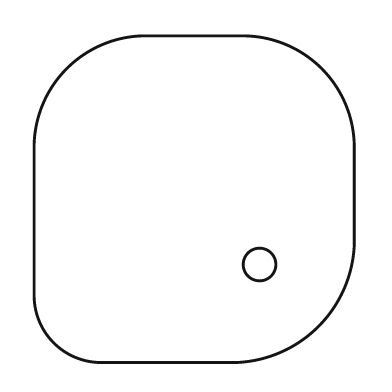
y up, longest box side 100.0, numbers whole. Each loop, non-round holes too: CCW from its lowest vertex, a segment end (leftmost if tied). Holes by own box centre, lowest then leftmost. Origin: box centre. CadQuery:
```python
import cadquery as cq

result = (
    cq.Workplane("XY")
    .moveTo(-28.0, -50.0)
    .lineTo(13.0, -50.0)
    .threePointArc((38.0, -39.0), (49.0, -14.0))
    .lineTo(49.0, 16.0)
    .threePointArc((39.0, 40.0), (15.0, 50.0))
    .lineTo(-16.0, 50.0)
    .threePointArc((-39.0, 40.0), (-49.0, 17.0))
    .lineTo(-49.0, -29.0)
    .threePointArc((-43.0, -44.0), (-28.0, -50.0))
    .close()
    .moveTo(20.0, -20.0)
    .circle(5.0)
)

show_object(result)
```